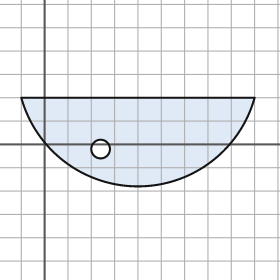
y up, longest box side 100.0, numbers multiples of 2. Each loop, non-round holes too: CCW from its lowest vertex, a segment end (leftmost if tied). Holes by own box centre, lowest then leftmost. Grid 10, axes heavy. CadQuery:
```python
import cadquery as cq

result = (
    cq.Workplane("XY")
    .moveTo(-10.0, 20.0)
    .threePointArc((40.0, -18.0), (90.0, 20.0))
    .close()
    .moveTo(24.0, -2.0)
    .circle(4.0)
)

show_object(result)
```